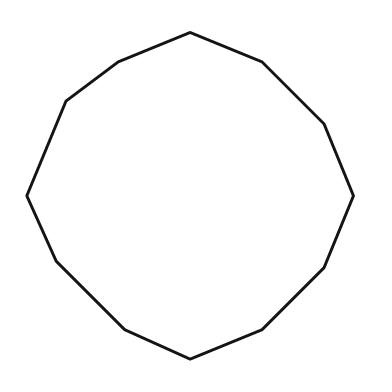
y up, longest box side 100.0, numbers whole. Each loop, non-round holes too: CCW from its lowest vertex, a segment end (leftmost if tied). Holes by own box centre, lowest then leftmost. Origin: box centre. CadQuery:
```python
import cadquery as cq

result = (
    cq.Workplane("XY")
    .moveTo(0.0, -50.0)
    .lineTo(22.0, -41.0)
    .lineTo(41.0, -22.0)
    .lineTo(50.0, 0.0)
    .lineTo(41.0, 22.0)
    .lineTo(22.0, 41.0)
    .lineTo(0.0, 50.0)
    .lineTo(-22.0, 41.0)
    .lineTo(-38.0, 29.0)
    .lineTo(-50.0, 0.0)
    .lineTo(-41.0, -20.0)
    .lineTo(-20.0, -41.0)
    .close()
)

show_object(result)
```